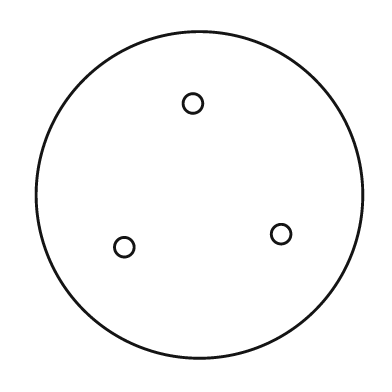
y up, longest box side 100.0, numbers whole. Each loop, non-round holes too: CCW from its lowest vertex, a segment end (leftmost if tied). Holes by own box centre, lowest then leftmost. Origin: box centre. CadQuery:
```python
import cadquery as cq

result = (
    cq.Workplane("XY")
    .moveTo(0.0, 0.0)
    .circle(50.0)
    .moveTo(-23.0, -16.0)
    .circle(3.0)
    .moveTo(25.0, -12.0)
    .circle(3.0)
    .moveTo(-2.0, 28.0)
    .circle(3.0)
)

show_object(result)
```